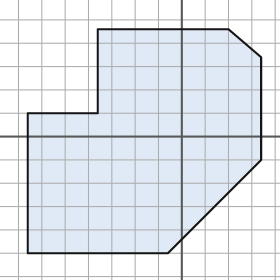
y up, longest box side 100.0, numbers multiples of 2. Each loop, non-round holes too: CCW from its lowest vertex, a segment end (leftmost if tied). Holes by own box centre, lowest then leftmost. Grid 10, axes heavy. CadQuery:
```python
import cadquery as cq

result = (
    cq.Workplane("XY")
    .moveTo(-66.0, -50.0)
    .lineTo(-6.0, -50.0)
    .lineTo(34.0, -10.0)
    .lineTo(34.0, 34.0)
    .lineTo(20.0, 46.0)
    .lineTo(-36.0, 46.0)
    .lineTo(-36.0, 10.0)
    .lineTo(-66.0, 10.0)
    .close()
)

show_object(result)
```